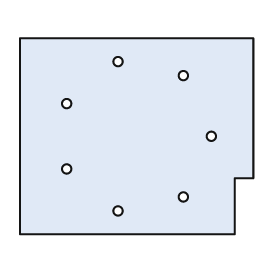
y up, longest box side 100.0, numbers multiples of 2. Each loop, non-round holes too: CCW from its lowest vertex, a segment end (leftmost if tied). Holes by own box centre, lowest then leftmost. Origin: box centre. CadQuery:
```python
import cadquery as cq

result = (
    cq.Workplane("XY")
    .moveTo(-50.0, -42.0)
    .lineTo(42.0, -42.0)
    .lineTo(42.0, -18.0)
    .lineTo(50.0, -18.0)
    .lineTo(50.0, 42.0)
    .lineTo(-50.0, 42.0)
    .close()
    .moveTo(-8.0, -32.0)
    .circle(2.0)
    .moveTo(20.0, -26.0)
    .circle(2.0)
    .moveTo(-30.0, -14.0)
    .circle(2.0)
    .moveTo(32.0, 0.0)
    .circle(2.0)
    .moveTo(-30.0, 14.0)
    .circle(2.0)
    .moveTo(20.0, 26.0)
    .circle(2.0)
    .moveTo(-8.0, 32.0)
    .circle(2.0)
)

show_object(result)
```